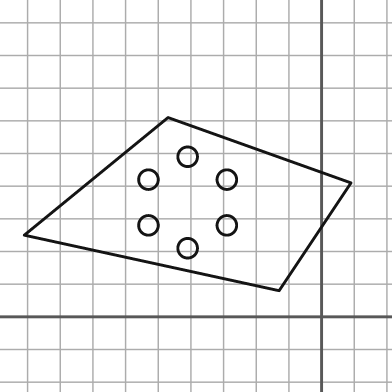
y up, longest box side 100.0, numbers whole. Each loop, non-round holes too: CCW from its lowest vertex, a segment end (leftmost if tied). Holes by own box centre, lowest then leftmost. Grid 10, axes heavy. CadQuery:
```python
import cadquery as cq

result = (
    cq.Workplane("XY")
    .moveTo(-13.0, 8.0)
    .lineTo(9.0, 41.0)
    .lineTo(-47.0, 61.0)
    .lineTo(-91.0, 25.0)
    .close()
    .moveTo(-41.0, 21.0)
    .circle(3.0)
    .moveTo(-53.0, 28.0)
    .circle(3.0)
    .moveTo(-29.0, 28.0)
    .circle(3.0)
    .moveTo(-53.0, 42.0)
    .circle(3.0)
    .moveTo(-29.0, 42.0)
    .circle(3.0)
    .moveTo(-41.0, 49.0)
    .circle(3.0)
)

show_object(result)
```